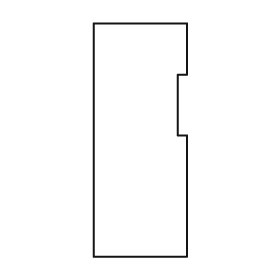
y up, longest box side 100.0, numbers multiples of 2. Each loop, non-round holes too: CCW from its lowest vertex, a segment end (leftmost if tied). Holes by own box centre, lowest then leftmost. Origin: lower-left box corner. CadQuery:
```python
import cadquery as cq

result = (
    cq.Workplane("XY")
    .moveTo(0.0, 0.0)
    .lineTo(40.0, 0.0)
    .lineTo(40.0, 52.0)
    .lineTo(36.0, 52.0)
    .lineTo(36.0, 78.0)
    .lineTo(40.0, 78.0)
    .lineTo(40.0, 100.0)
    .lineTo(0.0, 100.0)
    .close()
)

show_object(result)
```